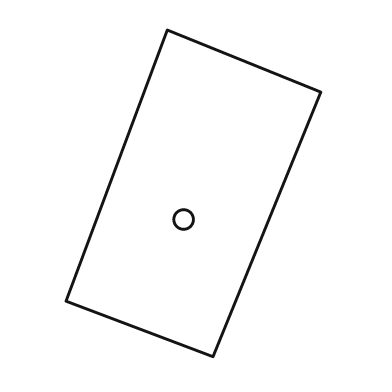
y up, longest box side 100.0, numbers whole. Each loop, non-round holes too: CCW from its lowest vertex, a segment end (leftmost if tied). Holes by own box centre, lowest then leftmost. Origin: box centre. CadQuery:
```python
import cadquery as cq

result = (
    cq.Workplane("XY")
    .moveTo(6.0, -50.0)
    .lineTo(39.0, 31.0)
    .lineTo(-8.0, 50.0)
    .lineTo(-39.0, -33.0)
    .close()
    .moveTo(-3.0, -8.0)
    .circle(3.0)
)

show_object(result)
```